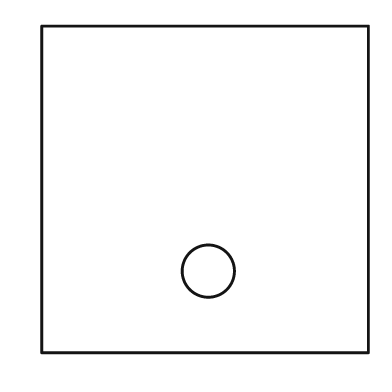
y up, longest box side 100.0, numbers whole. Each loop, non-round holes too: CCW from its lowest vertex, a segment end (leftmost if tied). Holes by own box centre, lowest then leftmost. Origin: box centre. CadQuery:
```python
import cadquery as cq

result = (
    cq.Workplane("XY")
    .moveTo(-50.0, -50.0)
    .lineTo(50.0, -50.0)
    .lineTo(50.0, 50.0)
    .lineTo(-50.0, 50.0)
    .close()
    .moveTo(1.0, -25.0)
    .circle(8.0)
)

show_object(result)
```